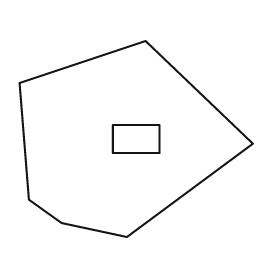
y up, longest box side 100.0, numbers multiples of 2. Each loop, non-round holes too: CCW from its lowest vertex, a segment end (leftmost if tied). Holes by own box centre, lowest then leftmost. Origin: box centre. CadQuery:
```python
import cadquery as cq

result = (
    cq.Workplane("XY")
    .moveTo(-4.0, -42.0)
    .lineTo(50.0, -2.0)
    .lineTo(4.0, 42.0)
    .lineTo(-50.0, 24.0)
    .lineTo(-46.0, -26.0)
    .lineTo(-32.0, -36.0)
    .close()
    .moveTo(-10.0, -6.0)
    .lineTo(10.0, -6.0)
    .lineTo(10.0, 6.0)
    .lineTo(-10.0, 6.0)
    .close()
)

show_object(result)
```